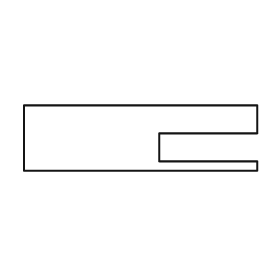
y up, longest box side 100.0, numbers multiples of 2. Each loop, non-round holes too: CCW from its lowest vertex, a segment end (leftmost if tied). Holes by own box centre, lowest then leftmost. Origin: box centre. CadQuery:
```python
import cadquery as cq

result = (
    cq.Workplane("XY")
    .moveTo(-50.0, -14.0)
    .lineTo(50.0, -14.0)
    .lineTo(50.0, -10.0)
    .lineTo(8.0, -10.0)
    .lineTo(8.0, 2.0)
    .lineTo(50.0, 2.0)
    .lineTo(50.0, 14.0)
    .lineTo(-50.0, 14.0)
    .close()
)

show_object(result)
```